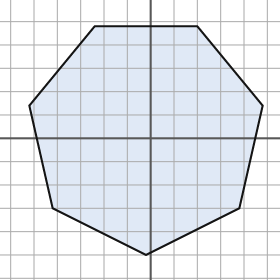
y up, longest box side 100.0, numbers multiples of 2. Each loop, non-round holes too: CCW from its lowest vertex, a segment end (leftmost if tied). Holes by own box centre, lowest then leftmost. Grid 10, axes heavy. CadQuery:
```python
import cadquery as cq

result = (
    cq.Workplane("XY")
    .moveTo(-2.0, -50.0)
    .lineTo(38.0, -30.0)
    .lineTo(48.0, 14.0)
    .lineTo(20.0, 48.0)
    .lineTo(-24.0, 48.0)
    .lineTo(-52.0, 14.0)
    .lineTo(-42.0, -30.0)
    .close()
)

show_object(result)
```